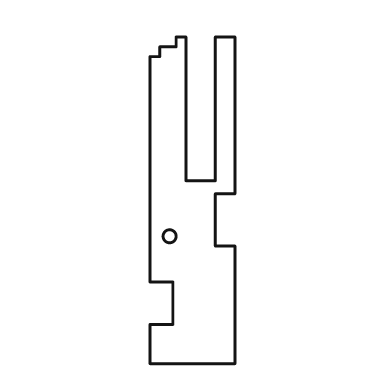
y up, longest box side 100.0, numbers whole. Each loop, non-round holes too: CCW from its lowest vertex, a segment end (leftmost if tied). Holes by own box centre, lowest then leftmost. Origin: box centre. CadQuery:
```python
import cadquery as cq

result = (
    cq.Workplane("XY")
    .moveTo(-13.0, -50.0)
    .lineTo(13.0, -50.0)
    .lineTo(13.0, -14.0)
    .lineTo(7.0, -14.0)
    .lineTo(7.0, 2.0)
    .lineTo(13.0, 2.0)
    .lineTo(13.0, 50.0)
    .lineTo(7.0, 50.0)
    .lineTo(7.0, 6.0)
    .lineTo(-2.0, 6.0)
    .lineTo(-2.0, 50.0)
    .lineTo(-5.0, 50.0)
    .lineTo(-5.0, 47.0)
    .lineTo(-10.0, 47.0)
    .lineTo(-10.0, 44.0)
    .lineTo(-13.0, 44.0)
    .lineTo(-13.0, -25.0)
    .lineTo(-6.0, -25.0)
    .lineTo(-6.0, -38.0)
    .lineTo(-13.0, -38.0)
    .close()
    .moveTo(-7.0, -11.0)
    .circle(2.0)
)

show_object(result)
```